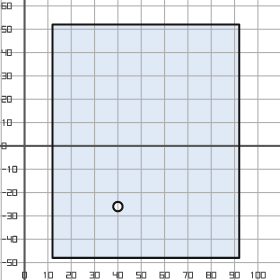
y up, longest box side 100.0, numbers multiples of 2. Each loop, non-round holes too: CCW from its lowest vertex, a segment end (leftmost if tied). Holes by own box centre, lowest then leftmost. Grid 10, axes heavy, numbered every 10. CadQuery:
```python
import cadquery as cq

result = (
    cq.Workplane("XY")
    .moveTo(12.0, -48.0)
    .lineTo(92.0, -48.0)
    .lineTo(92.0, 52.0)
    .lineTo(12.0, 52.0)
    .close()
    .moveTo(40.0, -26.0)
    .circle(2.0)
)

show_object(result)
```